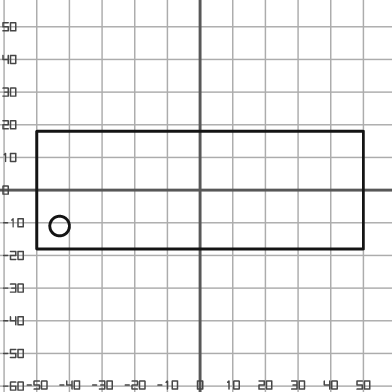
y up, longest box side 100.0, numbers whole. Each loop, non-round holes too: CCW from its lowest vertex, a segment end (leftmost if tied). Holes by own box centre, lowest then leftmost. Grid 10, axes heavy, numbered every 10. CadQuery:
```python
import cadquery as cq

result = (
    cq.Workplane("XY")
    .moveTo(-50.0, -18.0)
    .lineTo(50.0, -18.0)
    .lineTo(50.0, 18.0)
    .lineTo(-50.0, 18.0)
    .close()
    .moveTo(-43.0, -11.0)
    .circle(3.0)
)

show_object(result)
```